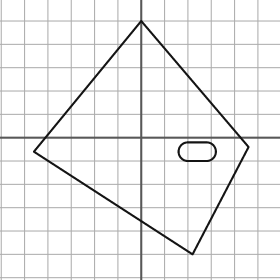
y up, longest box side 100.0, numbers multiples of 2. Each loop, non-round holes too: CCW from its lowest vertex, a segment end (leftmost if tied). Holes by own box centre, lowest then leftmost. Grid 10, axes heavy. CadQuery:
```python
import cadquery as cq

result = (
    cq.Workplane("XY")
    .moveTo(22.0, -50.0)
    .lineTo(46.0, -4.0)
    .lineTo(0.0, 50.0)
    .lineTo(-46.0, -6.0)
    .close()
    .moveTo(20.0, -10.0)
    .lineTo(28.0, -10.0)
    .threePointArc((32.0, -6.0), (28.0, -2.0))
    .lineTo(20.0, -2.0)
    .threePointArc((16.0, -6.0), (20.0, -10.0))
    .close()
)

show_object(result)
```